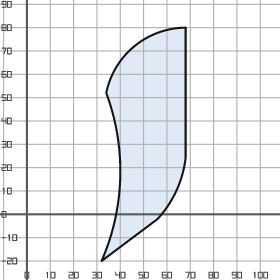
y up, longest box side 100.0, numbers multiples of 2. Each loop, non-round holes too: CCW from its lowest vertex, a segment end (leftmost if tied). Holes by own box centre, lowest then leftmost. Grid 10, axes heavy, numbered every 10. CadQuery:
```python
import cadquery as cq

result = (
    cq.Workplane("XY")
    .moveTo(32.0, -20.0)
    .lineTo(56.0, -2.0)
    .threePointArc((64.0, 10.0), (68.0, 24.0))
    .lineTo(68.0, 80.0)
    .threePointArc((46.0, 72.0), (34.0, 52.0))
    .threePointArc((40.0, 16.0), (32.0, -20.0))
    .close()
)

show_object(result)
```